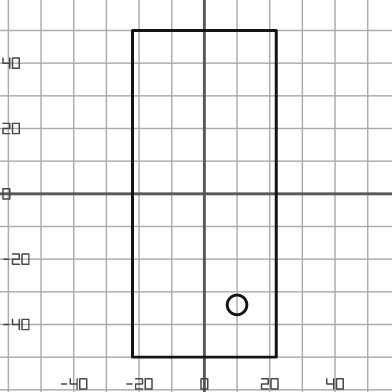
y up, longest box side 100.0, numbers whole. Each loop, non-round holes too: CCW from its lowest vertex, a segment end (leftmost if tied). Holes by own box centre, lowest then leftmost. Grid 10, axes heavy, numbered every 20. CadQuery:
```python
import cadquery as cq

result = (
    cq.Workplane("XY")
    .moveTo(-22.0, -50.0)
    .lineTo(22.0, -50.0)
    .lineTo(22.0, 50.0)
    .lineTo(-22.0, 50.0)
    .close()
    .moveTo(10.0, -34.0)
    .circle(3.0)
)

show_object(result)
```